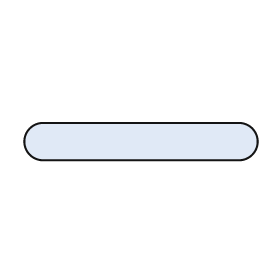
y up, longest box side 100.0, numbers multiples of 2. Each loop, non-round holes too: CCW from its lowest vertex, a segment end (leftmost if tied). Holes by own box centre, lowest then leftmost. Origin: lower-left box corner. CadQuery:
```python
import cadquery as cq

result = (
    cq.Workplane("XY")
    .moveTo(8.0, 0.0)
    .lineTo(92.0, 0.0)
    .threePointArc((100.0, 8.0), (92.0, 16.0))
    .lineTo(8.0, 16.0)
    .threePointArc((0.0, 8.0), (8.0, 0.0))
    .close()
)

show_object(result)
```